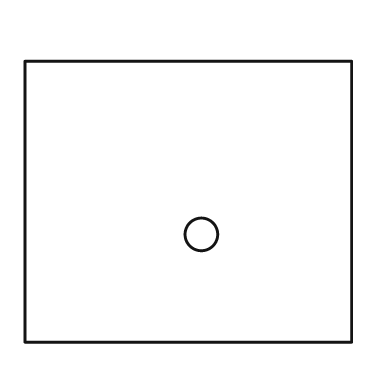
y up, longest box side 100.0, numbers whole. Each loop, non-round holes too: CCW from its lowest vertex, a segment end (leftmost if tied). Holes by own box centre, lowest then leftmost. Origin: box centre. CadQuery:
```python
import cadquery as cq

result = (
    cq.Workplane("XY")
    .moveTo(-50.0, -43.0)
    .lineTo(50.0, -43.0)
    .lineTo(50.0, 43.0)
    .lineTo(-50.0, 43.0)
    .close()
    .moveTo(4.0, -10.0)
    .circle(5.0)
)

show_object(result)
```